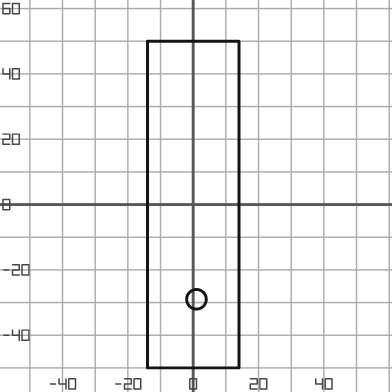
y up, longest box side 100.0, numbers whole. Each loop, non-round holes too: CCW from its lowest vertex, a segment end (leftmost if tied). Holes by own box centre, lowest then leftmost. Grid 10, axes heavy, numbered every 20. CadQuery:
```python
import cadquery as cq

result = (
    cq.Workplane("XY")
    .moveTo(-14.0, -50.0)
    .lineTo(14.0, -50.0)
    .lineTo(14.0, 50.0)
    .lineTo(-14.0, 50.0)
    .close()
    .moveTo(1.0, -29.0)
    .circle(3.0)
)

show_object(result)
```